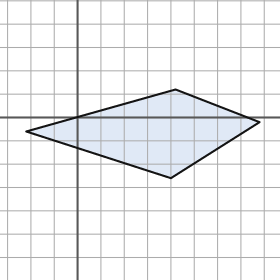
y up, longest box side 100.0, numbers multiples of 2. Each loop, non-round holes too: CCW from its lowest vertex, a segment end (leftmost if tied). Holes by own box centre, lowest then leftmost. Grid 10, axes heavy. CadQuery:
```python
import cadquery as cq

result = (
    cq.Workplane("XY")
    .moveTo(40.0, -26.0)
    .lineTo(78.0, -2.0)
    .lineTo(42.0, 12.0)
    .lineTo(-22.0, -6.0)
    .close()
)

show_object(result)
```